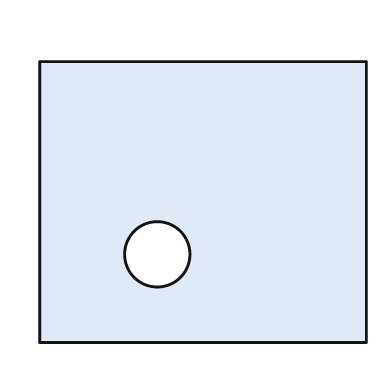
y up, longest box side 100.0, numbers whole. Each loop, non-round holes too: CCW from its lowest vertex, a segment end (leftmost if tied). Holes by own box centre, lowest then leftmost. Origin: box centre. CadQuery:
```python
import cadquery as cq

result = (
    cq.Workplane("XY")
    .moveTo(-50.0, -43.0)
    .lineTo(50.0, -43.0)
    .lineTo(50.0, 43.0)
    .lineTo(-50.0, 43.0)
    .close()
    .moveTo(-14.0, -16.0)
    .circle(10.0)
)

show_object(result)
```